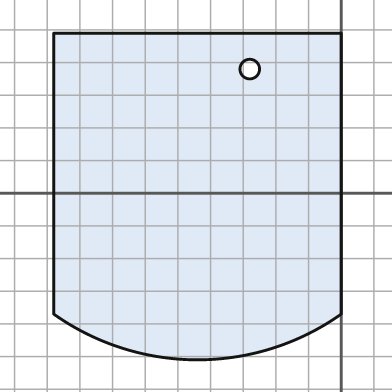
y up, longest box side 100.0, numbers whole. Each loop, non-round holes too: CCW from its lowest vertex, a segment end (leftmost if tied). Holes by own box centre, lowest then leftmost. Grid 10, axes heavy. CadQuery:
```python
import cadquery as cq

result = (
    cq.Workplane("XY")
    .moveTo(-88.0, -37.0)
    .threePointArc((-44.0, -51.0), (0.0, -37.0))
    .lineTo(0.0, 49.0)
    .lineTo(-88.0, 49.0)
    .close()
    .moveTo(-28.0, 38.0)
    .circle(3.0)
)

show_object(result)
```